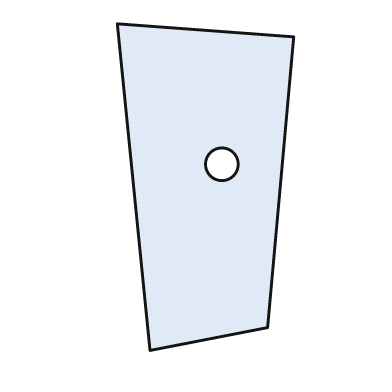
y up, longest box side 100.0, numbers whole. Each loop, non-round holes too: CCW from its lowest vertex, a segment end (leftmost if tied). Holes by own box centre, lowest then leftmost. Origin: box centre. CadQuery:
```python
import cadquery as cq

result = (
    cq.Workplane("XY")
    .moveTo(-17.0, -50.0)
    .lineTo(19.0, -43.0)
    .lineTo(27.0, 46.0)
    .lineTo(-27.0, 50.0)
    .close()
    .moveTo(5.0, 7.0)
    .circle(5.0)
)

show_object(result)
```